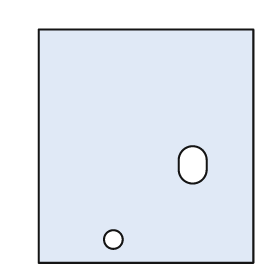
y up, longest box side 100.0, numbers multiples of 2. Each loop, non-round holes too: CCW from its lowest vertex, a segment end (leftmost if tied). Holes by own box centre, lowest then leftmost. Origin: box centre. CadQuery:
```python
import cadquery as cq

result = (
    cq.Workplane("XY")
    .moveTo(-46.0, -50.0)
    .lineTo(46.0, -50.0)
    .lineTo(46.0, 50.0)
    .lineTo(-46.0, 50.0)
    .close()
    .moveTo(-14.0, -40.0)
    .circle(4.0)
    .moveTo(14.0, -10.0)
    .threePointArc((20.0, -16.0), (26.0, -10.0))
    .lineTo(26.0, -6.0)
    .threePointArc((20.0, 0.0), (14.0, -6.0))
    .close()
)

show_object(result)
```